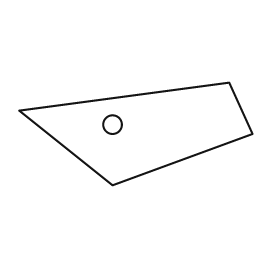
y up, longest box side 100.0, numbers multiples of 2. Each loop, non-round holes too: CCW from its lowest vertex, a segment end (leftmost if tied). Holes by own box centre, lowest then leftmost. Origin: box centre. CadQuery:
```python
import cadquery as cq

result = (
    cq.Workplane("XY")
    .moveTo(-10.0, -22.0)
    .lineTo(50.0, 0.0)
    .lineTo(40.0, 22.0)
    .lineTo(-50.0, 10.0)
    .close()
    .moveTo(-10.0, 4.0)
    .circle(4.0)
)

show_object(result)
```